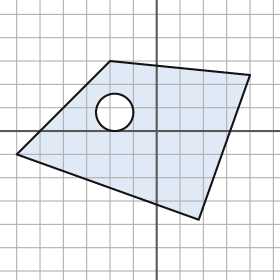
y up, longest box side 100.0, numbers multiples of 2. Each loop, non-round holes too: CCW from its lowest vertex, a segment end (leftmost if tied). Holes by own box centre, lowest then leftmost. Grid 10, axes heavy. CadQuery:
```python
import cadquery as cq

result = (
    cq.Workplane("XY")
    .moveTo(18.0, -38.0)
    .lineTo(40.0, 24.0)
    .lineTo(-20.0, 30.0)
    .lineTo(-60.0, -10.0)
    .close()
    .moveTo(-18.0, 8.0)
    .circle(8.0)
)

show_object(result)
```